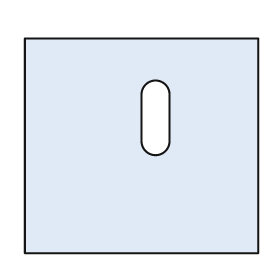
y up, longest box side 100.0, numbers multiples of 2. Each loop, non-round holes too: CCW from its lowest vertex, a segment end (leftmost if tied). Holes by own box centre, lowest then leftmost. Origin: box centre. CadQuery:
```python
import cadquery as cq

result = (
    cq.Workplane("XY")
    .moveTo(-50.0, -46.0)
    .lineTo(50.0, -46.0)
    .lineTo(50.0, 46.0)
    .lineTo(-50.0, 46.0)
    .close()
    .moveTo(0.0, 2.0)
    .threePointArc((6.0, -4.0), (12.0, 2.0))
    .lineTo(12.0, 22.0)
    .threePointArc((6.0, 28.0), (0.0, 22.0))
    .close()
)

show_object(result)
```